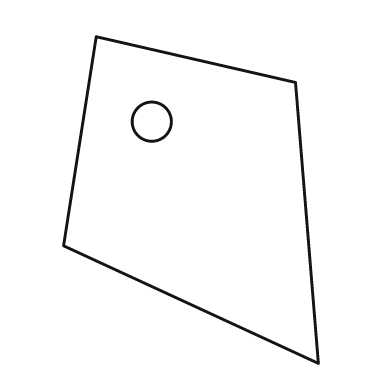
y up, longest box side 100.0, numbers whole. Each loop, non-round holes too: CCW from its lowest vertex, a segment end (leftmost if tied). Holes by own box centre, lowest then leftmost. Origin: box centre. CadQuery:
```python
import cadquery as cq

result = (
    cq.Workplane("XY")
    .moveTo(39.0, -50.0)
    .lineTo(32.0, 36.0)
    .lineTo(-29.0, 50.0)
    .lineTo(-39.0, -14.0)
    .close()
    .moveTo(-12.0, 24.0)
    .circle(6.0)
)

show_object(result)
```